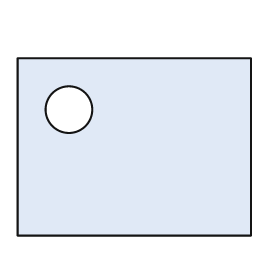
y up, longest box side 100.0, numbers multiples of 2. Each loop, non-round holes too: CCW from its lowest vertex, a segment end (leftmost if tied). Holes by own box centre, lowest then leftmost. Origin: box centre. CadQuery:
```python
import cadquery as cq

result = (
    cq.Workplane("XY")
    .moveTo(-50.0, -38.0)
    .lineTo(50.0, -38.0)
    .lineTo(50.0, 38.0)
    .lineTo(-50.0, 38.0)
    .close()
    .moveTo(-28.0, 16.0)
    .circle(10.0)
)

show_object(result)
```